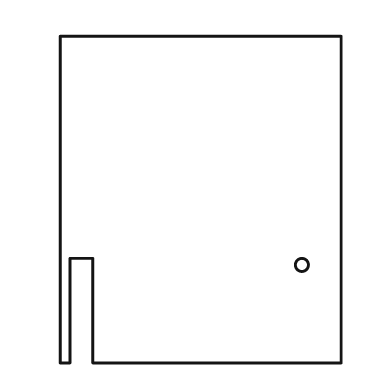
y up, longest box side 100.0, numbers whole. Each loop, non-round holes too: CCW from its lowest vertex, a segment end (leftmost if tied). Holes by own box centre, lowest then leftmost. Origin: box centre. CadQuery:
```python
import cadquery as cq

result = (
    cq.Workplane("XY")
    .moveTo(-43.0, -50.0)
    .lineTo(-40.0, -50.0)
    .lineTo(-40.0, -18.0)
    .lineTo(-33.0, -18.0)
    .lineTo(-33.0, -50.0)
    .lineTo(43.0, -50.0)
    .lineTo(43.0, 50.0)
    .lineTo(-43.0, 50.0)
    .close()
    .moveTo(31.0, -20.0)
    .circle(2.0)
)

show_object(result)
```